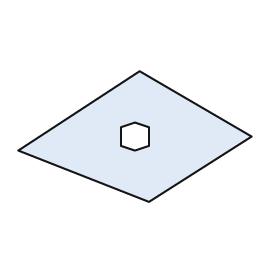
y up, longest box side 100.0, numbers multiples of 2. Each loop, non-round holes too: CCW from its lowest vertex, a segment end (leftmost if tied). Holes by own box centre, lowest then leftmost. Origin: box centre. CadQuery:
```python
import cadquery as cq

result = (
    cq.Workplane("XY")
    .moveTo(6.0, -28.0)
    .lineTo(50.0, 0.0)
    .lineTo(2.0, 28.0)
    .lineTo(-50.0, -6.0)
    .close()
    .moveTo(0.0, -6.0)
    .lineTo(6.0, -4.0)
    .lineTo(6.0, 4.0)
    .lineTo(0.0, 6.0)
    .lineTo(-6.0, 4.0)
    .lineTo(-6.0, -4.0)
    .close()
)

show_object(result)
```